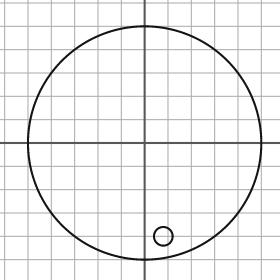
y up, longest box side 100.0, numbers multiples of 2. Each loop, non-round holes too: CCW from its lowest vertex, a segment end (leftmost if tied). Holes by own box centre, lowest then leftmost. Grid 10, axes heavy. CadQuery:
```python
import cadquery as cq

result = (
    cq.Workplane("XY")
    .moveTo(0.0, 0.0)
    .circle(50.0)
    .moveTo(8.0, -40.0)
    .circle(4.0)
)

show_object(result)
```